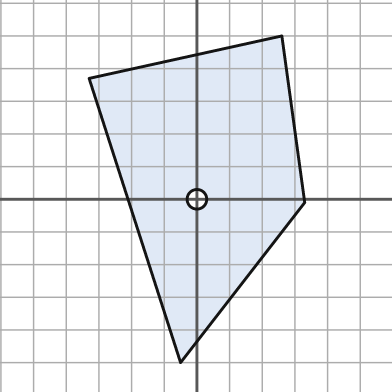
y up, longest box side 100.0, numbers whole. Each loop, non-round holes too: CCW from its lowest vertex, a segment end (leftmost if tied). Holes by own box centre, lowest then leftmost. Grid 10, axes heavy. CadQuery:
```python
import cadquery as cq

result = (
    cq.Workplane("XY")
    .moveTo(-5.0, -50.0)
    .lineTo(33.0, -1.0)
    .lineTo(26.0, 50.0)
    .lineTo(-33.0, 37.0)
    .close()
    .moveTo(0.0, 0.0)
    .circle(3.0)
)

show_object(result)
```